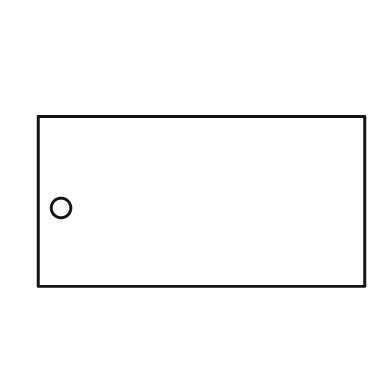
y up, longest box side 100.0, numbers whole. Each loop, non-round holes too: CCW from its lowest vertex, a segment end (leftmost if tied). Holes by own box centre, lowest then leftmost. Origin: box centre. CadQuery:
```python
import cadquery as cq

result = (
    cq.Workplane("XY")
    .moveTo(-50.0, -26.0)
    .lineTo(50.0, -26.0)
    .lineTo(50.0, 26.0)
    .lineTo(-50.0, 26.0)
    .close()
    .moveTo(-43.0, -2.0)
    .circle(3.0)
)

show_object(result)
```